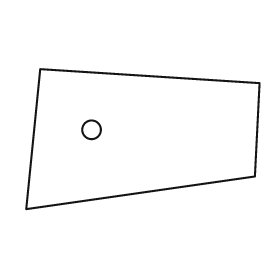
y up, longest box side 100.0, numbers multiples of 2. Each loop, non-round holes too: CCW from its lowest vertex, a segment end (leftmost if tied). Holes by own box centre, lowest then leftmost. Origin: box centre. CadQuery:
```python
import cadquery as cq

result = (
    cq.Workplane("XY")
    .moveTo(-50.0, -30.0)
    .lineTo(48.0, -16.0)
    .lineTo(50.0, 24.0)
    .lineTo(-44.0, 30.0)
    .close()
    .moveTo(-22.0, 4.0)
    .circle(4.0)
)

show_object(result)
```